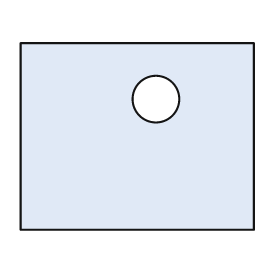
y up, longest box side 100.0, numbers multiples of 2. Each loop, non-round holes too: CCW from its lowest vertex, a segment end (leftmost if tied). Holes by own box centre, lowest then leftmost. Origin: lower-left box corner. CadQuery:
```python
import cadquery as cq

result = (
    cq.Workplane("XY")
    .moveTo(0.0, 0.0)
    .lineTo(100.0, 0.0)
    .lineTo(100.0, 80.0)
    .lineTo(0.0, 80.0)
    .close()
    .moveTo(58.0, 56.0)
    .circle(10.0)
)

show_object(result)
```